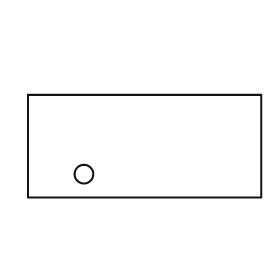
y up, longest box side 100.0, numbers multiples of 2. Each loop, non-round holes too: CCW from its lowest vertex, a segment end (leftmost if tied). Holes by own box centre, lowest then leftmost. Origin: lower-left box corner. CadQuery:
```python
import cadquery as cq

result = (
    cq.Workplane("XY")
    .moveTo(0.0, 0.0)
    .lineTo(100.0, 0.0)
    .lineTo(100.0, 44.0)
    .lineTo(0.0, 44.0)
    .close()
    .moveTo(24.0, 10.0)
    .circle(4.0)
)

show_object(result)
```